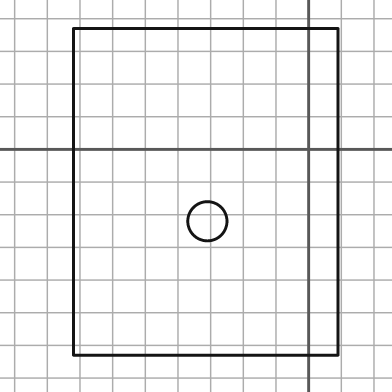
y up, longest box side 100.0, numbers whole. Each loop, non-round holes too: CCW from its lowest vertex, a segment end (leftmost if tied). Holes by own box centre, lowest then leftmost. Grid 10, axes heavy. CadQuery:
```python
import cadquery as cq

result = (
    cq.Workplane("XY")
    .moveTo(-72.0, -63.0)
    .lineTo(9.0, -63.0)
    .lineTo(9.0, 37.0)
    .lineTo(-72.0, 37.0)
    .close()
    .moveTo(-31.0, -22.0)
    .circle(6.0)
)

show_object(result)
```